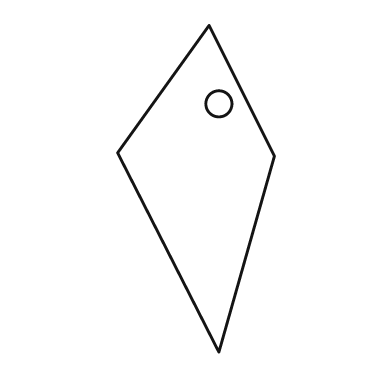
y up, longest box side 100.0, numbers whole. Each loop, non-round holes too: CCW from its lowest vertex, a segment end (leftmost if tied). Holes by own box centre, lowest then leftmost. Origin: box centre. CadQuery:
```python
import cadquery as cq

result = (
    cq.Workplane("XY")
    .moveTo(7.0, -50.0)
    .lineTo(24.0, 10.0)
    .lineTo(4.0, 50.0)
    .lineTo(-24.0, 11.0)
    .close()
    .moveTo(7.0, 26.0)
    .circle(4.0)
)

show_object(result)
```